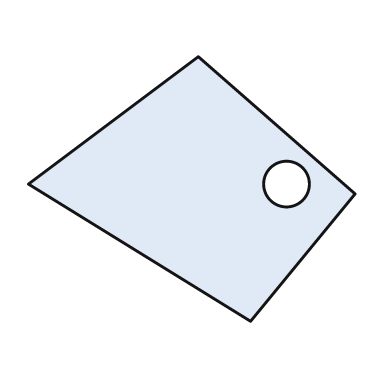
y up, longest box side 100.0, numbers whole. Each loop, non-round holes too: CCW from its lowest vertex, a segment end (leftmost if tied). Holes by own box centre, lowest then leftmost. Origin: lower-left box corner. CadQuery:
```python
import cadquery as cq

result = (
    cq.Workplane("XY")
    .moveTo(68.0, 0.0)
    .lineTo(100.0, 39.0)
    .lineTo(52.0, 81.0)
    .lineTo(0.0, 42.0)
    .close()
    .moveTo(79.0, 42.0)
    .circle(7.0)
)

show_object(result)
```